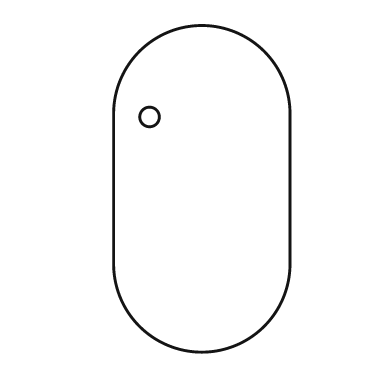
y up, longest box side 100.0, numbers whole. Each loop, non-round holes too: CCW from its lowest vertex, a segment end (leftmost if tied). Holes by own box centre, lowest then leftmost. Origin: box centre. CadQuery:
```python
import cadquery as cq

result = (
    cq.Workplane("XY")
    .moveTo(-27.0, -23.0)
    .threePointArc((0.0, -50.0), (27.0, -23.0))
    .lineTo(27.0, 23.0)
    .threePointArc((0.0, 50.0), (-27.0, 23.0))
    .close()
    .moveTo(-16.0, 22.0)
    .circle(3.0)
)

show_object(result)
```